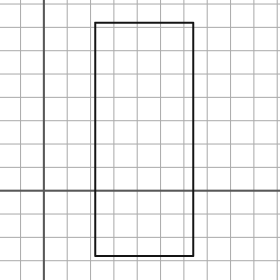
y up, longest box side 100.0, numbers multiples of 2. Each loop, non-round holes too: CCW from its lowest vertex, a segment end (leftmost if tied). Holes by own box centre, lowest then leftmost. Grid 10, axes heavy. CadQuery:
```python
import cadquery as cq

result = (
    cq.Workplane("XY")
    .moveTo(22.0, -28.0)
    .lineTo(64.0, -28.0)
    .lineTo(64.0, 72.0)
    .lineTo(22.0, 72.0)
    .close()
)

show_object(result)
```